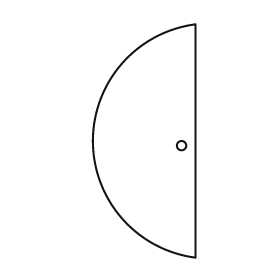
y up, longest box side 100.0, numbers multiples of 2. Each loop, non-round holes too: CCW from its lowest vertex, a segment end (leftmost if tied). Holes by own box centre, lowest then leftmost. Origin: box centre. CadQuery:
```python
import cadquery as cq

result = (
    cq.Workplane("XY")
    .moveTo(22.0, -50.0)
    .lineTo(22.0, 50.0)
    .threePointArc((-22.0, 0.0), (22.0, -50.0))
    .close()
    .moveTo(16.0, -2.0)
    .circle(2.0)
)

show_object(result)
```